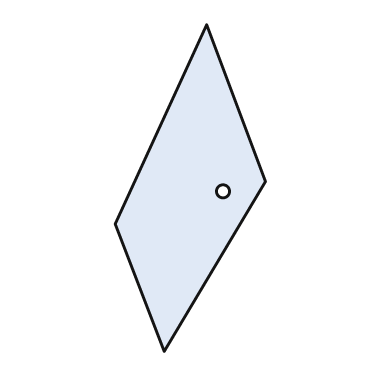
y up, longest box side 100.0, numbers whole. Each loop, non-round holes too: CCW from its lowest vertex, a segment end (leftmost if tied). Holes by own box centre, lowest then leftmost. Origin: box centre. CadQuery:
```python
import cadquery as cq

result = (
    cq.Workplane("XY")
    .moveTo(-8.0, -50.0)
    .lineTo(23.0, 2.0)
    .lineTo(5.0, 50.0)
    .lineTo(-23.0, -11.0)
    .close()
    .moveTo(10.0, -1.0)
    .circle(2.0)
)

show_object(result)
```